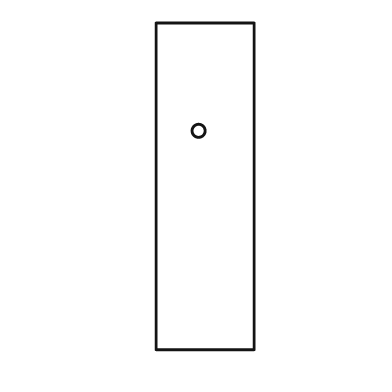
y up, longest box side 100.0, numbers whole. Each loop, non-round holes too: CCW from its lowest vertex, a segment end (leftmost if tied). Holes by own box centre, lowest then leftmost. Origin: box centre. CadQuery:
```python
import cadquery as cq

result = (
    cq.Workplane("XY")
    .moveTo(-15.0, -50.0)
    .lineTo(15.0, -50.0)
    .lineTo(15.0, 50.0)
    .lineTo(-15.0, 50.0)
    .close()
    .moveTo(-2.0, 17.0)
    .circle(2.0)
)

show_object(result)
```